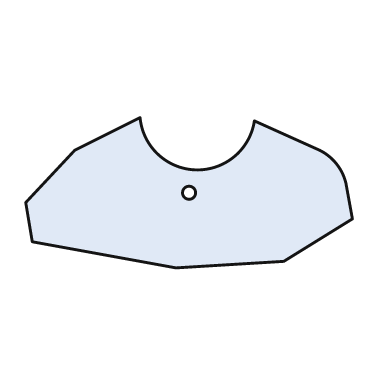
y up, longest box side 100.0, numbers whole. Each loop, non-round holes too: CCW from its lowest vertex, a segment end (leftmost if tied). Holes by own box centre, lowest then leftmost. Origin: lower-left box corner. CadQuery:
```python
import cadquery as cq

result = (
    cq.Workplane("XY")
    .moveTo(46.0, 0.0)
    .lineTo(79.0, 2.0)
    .lineTo(100.0, 15.0)
    .lineTo(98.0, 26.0)
    .threePointArc((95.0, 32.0), (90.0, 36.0))
    .lineTo(70.0, 45.0)
    .threePointArc((52.0, 30.0), (35.0, 46.0))
    .lineTo(15.0, 36.0)
    .lineTo(0.0, 20.0)
    .lineTo(2.0, 8.0)
    .close()
    .moveTo(50.0, 23.0)
    .circle(2.0)
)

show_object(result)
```